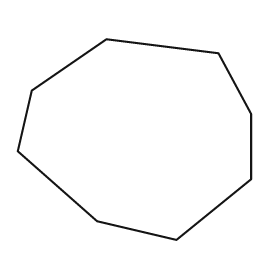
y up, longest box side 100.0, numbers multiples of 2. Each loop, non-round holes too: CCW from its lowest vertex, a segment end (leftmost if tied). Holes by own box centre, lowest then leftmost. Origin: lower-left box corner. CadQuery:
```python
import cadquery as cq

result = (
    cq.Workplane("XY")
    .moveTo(68.0, 0.0)
    .lineTo(100.0, 26.0)
    .lineTo(100.0, 54.0)
    .lineTo(86.0, 80.0)
    .lineTo(38.0, 86.0)
    .lineTo(6.0, 64.0)
    .lineTo(0.0, 38.0)
    .lineTo(34.0, 8.0)
    .close()
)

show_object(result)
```